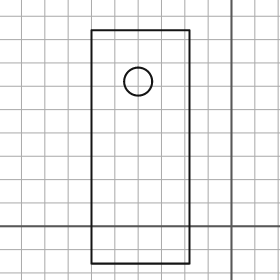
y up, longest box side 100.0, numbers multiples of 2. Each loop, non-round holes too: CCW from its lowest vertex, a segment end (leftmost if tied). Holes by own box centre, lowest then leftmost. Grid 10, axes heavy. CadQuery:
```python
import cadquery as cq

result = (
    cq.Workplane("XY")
    .moveTo(-60.0, -16.0)
    .lineTo(-18.0, -16.0)
    .lineTo(-18.0, 84.0)
    .lineTo(-60.0, 84.0)
    .close()
    .moveTo(-40.0, 62.0)
    .circle(6.0)
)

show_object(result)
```